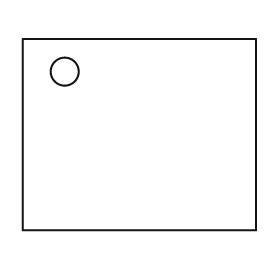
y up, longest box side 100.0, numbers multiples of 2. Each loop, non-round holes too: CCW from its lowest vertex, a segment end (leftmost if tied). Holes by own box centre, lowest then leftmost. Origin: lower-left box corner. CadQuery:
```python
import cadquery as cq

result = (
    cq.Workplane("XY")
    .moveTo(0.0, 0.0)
    .lineTo(100.0, 0.0)
    .lineTo(100.0, 82.0)
    .lineTo(0.0, 82.0)
    .close()
    .moveTo(18.0, 68.0)
    .circle(6.0)
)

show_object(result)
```